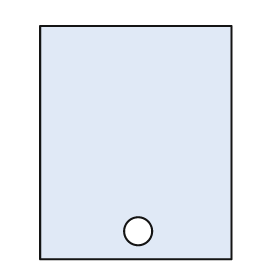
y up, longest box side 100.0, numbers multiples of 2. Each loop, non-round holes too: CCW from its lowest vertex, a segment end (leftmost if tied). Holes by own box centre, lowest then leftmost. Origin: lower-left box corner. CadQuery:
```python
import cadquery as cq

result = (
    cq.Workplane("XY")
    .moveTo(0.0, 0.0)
    .lineTo(82.0, 0.0)
    .lineTo(82.0, 100.0)
    .lineTo(0.0, 100.0)
    .close()
    .moveTo(42.0, 12.0)
    .circle(6.0)
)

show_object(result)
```